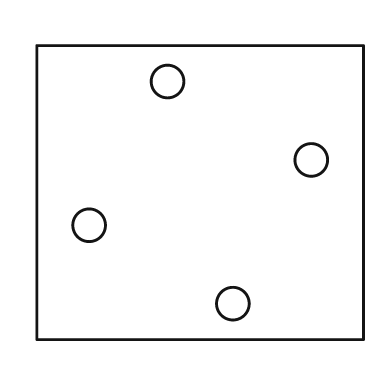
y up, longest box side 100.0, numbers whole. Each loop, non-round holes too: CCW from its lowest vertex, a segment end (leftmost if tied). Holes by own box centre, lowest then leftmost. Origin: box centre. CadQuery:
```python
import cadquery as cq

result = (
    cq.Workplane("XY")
    .moveTo(-50.0, -45.0)
    .lineTo(50.0, -45.0)
    .lineTo(50.0, 45.0)
    .lineTo(-50.0, 45.0)
    .close()
    .moveTo(10.0, -34.0)
    .circle(5.0)
    .moveTo(-34.0, -10.0)
    .circle(5.0)
    .moveTo(34.0, 10.0)
    .circle(5.0)
    .moveTo(-10.0, 34.0)
    .circle(5.0)
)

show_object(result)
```